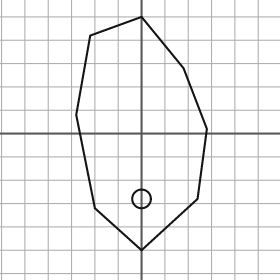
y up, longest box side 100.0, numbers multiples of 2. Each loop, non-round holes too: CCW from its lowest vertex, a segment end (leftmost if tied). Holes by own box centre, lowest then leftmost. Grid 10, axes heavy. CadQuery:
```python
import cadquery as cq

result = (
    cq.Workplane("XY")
    .moveTo(0.0, -50.0)
    .lineTo(24.0, -28.0)
    .lineTo(28.0, 2.0)
    .lineTo(18.0, 28.0)
    .lineTo(0.0, 50.0)
    .lineTo(-22.0, 42.0)
    .lineTo(-28.0, 8.0)
    .lineTo(-20.0, -32.0)
    .close()
    .moveTo(0.0, -28.0)
    .circle(4.0)
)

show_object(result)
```